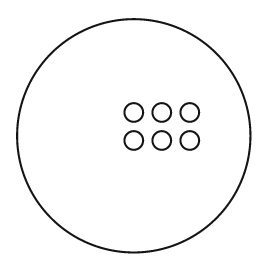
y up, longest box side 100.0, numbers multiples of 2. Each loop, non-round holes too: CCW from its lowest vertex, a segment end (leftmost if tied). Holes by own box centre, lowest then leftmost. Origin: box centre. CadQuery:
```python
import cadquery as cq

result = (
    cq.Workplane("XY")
    .moveTo(0.0, 0.0)
    .circle(50.0)
    .moveTo(0.0, -2.0)
    .circle(4.0)
    .moveTo(12.0, -2.0)
    .circle(4.0)
    .moveTo(24.0, -2.0)
    .circle(4.0)
    .moveTo(0.0, 10.0)
    .circle(4.0)
    .moveTo(12.0, 10.0)
    .circle(4.0)
    .moveTo(24.0, 10.0)
    .circle(4.0)
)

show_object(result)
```